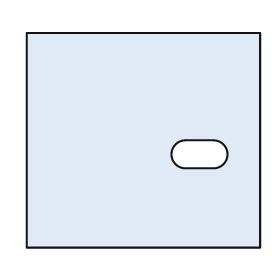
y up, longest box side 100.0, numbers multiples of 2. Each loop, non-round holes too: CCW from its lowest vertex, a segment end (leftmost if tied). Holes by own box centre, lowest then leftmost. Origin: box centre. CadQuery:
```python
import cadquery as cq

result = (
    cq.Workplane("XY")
    .moveTo(-50.0, -46.0)
    .lineTo(50.0, -46.0)
    .lineTo(50.0, 46.0)
    .lineTo(-50.0, 46.0)
    .close()
    .moveTo(18.0, -12.0)
    .lineTo(30.0, -12.0)
    .threePointArc((36.0, -6.0), (30.0, 0.0))
    .lineTo(18.0, 0.0)
    .threePointArc((12.0, -6.0), (18.0, -12.0))
    .close()
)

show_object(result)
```